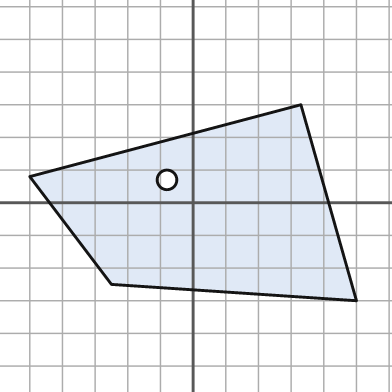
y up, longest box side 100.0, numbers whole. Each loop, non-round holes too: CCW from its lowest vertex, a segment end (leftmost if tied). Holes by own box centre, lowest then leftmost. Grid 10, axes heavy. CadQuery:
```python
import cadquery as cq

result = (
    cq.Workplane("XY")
    .moveTo(50.0, -30.0)
    .lineTo(33.0, 30.0)
    .lineTo(-50.0, 8.0)
    .lineTo(-25.0, -25.0)
    .close()
    .moveTo(-8.0, 7.0)
    .circle(3.0)
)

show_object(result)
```